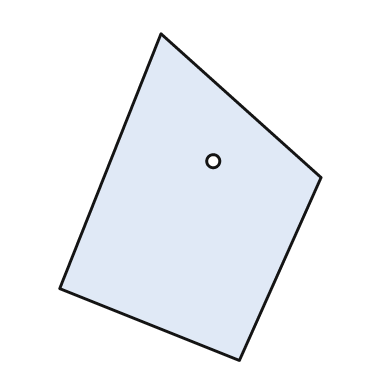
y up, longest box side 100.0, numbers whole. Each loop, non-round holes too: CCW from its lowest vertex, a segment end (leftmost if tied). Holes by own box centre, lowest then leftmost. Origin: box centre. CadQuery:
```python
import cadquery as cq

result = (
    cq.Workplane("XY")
    .moveTo(15.0, -50.0)
    .lineTo(40.0, 6.0)
    .lineTo(-9.0, 50.0)
    .lineTo(-40.0, -28.0)
    .close()
    .moveTo(7.0, 11.0)
    .circle(2.0)
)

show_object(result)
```